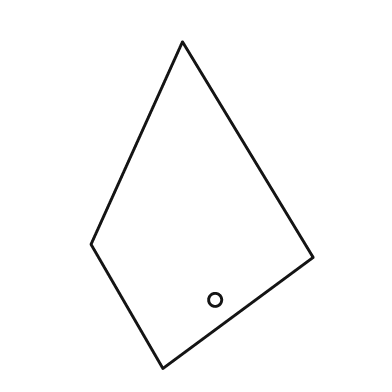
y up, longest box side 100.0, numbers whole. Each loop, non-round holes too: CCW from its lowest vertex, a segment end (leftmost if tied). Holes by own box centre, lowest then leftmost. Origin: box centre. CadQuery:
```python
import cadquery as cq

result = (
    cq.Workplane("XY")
    .moveTo(-12.0, -50.0)
    .lineTo(34.0, -16.0)
    .lineTo(-6.0, 50.0)
    .lineTo(-34.0, -12.0)
    .close()
    .moveTo(4.0, -29.0)
    .circle(2.0)
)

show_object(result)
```